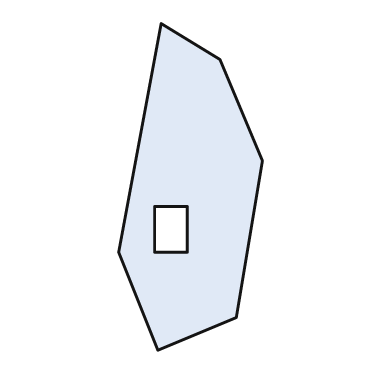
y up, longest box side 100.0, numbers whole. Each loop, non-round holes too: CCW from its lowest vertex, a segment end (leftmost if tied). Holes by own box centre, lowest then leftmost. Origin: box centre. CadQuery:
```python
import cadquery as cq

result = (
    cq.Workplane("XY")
    .moveTo(-10.0, -50.0)
    .lineTo(14.0, -40.0)
    .lineTo(22.0, 8.0)
    .lineTo(9.0, 39.0)
    .lineTo(-9.0, 50.0)
    .lineTo(-22.0, -20.0)
    .close()
    .moveTo(-11.0, -20.0)
    .lineTo(-1.0, -20.0)
    .lineTo(-1.0, -6.0)
    .lineTo(-11.0, -6.0)
    .close()
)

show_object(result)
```